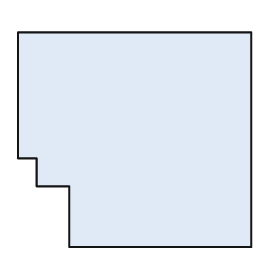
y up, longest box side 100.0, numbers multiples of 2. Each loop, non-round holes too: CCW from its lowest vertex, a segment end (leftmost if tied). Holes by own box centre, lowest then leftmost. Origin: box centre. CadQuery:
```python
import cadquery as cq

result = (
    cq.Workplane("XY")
    .moveTo(-28.0, -46.0)
    .lineTo(50.0, -46.0)
    .lineTo(50.0, 46.0)
    .lineTo(-50.0, 46.0)
    .lineTo(-50.0, -8.0)
    .lineTo(-42.0, -8.0)
    .lineTo(-42.0, -20.0)
    .lineTo(-28.0, -20.0)
    .close()
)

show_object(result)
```